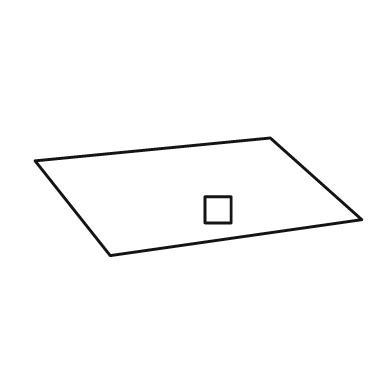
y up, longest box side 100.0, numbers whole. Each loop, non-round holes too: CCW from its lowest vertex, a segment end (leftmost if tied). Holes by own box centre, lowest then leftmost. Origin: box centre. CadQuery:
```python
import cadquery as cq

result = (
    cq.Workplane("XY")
    .moveTo(-27.0, -18.0)
    .lineTo(50.0, -7.0)
    .lineTo(22.0, 18.0)
    .lineTo(-50.0, 11.0)
    .close()
    .moveTo(2.0, -8.0)
    .lineTo(10.0, -8.0)
    .lineTo(10.0, 0.0)
    .lineTo(2.0, 0.0)
    .close()
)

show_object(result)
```